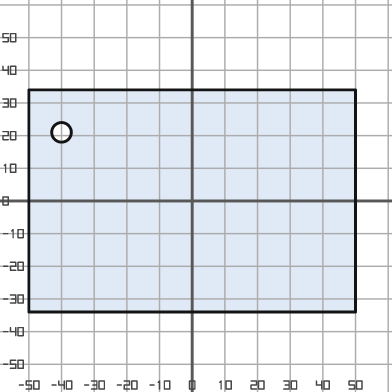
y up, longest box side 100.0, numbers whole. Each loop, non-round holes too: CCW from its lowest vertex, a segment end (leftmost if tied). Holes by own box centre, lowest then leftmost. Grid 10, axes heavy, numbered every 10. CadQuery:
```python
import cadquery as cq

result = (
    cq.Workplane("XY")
    .moveTo(-50.0, -34.0)
    .lineTo(50.0, -34.0)
    .lineTo(50.0, 34.0)
    .lineTo(-50.0, 34.0)
    .close()
    .moveTo(-40.0, 21.0)
    .circle(3.0)
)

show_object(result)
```